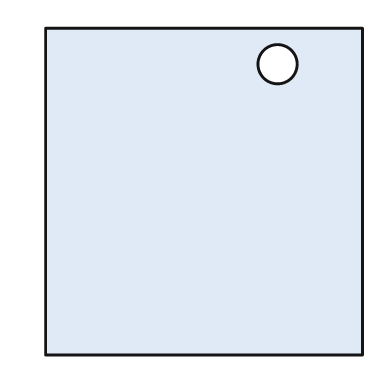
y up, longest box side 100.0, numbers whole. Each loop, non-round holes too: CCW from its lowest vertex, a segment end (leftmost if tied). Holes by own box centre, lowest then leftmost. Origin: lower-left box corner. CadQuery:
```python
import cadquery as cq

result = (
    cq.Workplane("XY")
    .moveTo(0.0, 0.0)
    .lineTo(97.0, 0.0)
    .lineTo(97.0, 100.0)
    .lineTo(0.0, 100.0)
    .close()
    .moveTo(71.0, 89.0)
    .circle(6.0)
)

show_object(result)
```